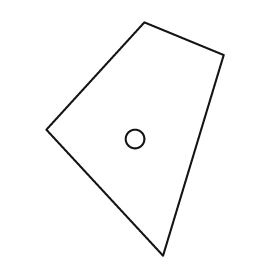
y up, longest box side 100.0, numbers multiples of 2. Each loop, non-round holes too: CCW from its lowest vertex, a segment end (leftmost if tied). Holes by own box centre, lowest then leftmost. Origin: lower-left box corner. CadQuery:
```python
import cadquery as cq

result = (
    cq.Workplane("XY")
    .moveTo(50.0, 0.0)
    .lineTo(76.0, 86.0)
    .lineTo(42.0, 100.0)
    .lineTo(0.0, 54.0)
    .close()
    .moveTo(38.0, 50.0)
    .circle(4.0)
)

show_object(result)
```